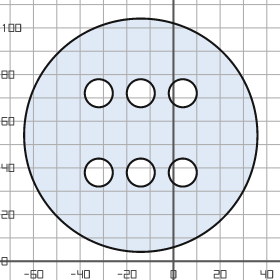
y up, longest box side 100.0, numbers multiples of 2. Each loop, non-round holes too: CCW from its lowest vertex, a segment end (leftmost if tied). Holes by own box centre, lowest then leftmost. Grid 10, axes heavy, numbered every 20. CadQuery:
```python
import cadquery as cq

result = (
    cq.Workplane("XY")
    .moveTo(-14.0, 54.0)
    .circle(50.0)
    .moveTo(-32.0, 38.0)
    .circle(6.0)
    .moveTo(-14.0, 38.0)
    .circle(6.0)
    .moveTo(4.0, 38.0)
    .circle(6.0)
    .moveTo(-32.0, 72.0)
    .circle(6.0)
    .moveTo(-14.0, 72.0)
    .circle(6.0)
    .moveTo(4.0, 72.0)
    .circle(6.0)
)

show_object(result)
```